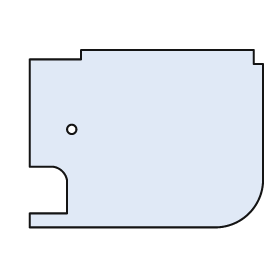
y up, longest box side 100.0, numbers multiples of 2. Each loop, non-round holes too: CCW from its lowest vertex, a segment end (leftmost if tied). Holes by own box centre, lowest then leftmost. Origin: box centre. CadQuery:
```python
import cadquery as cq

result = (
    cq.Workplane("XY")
    .moveTo(-50.0, -38.0)
    .lineTo(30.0, -38.0)
    .threePointArc((44.0, -32.0), (50.0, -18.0))
    .lineTo(50.0, 32.0)
    .lineTo(46.0, 32.0)
    .lineTo(46.0, 38.0)
    .lineTo(-28.0, 38.0)
    .lineTo(-28.0, 34.0)
    .lineTo(-50.0, 34.0)
    .lineTo(-50.0, -12.0)
    .lineTo(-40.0, -12.0)
    .threePointArc((-36.0, -14.0), (-34.0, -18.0))
    .lineTo(-34.0, -32.0)
    .lineTo(-50.0, -32.0)
    .close()
    .moveTo(-32.0, 4.0)
    .circle(2.0)
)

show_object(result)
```